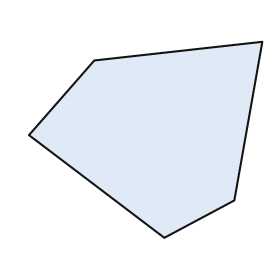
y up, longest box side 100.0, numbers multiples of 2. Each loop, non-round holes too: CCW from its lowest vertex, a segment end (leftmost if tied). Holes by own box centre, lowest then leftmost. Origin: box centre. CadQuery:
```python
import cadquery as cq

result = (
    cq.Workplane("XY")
    .moveTo(8.0, -42.0)
    .lineTo(38.0, -26.0)
    .lineTo(50.0, 42.0)
    .lineTo(-22.0, 34.0)
    .lineTo(-50.0, 2.0)
    .close()
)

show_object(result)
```